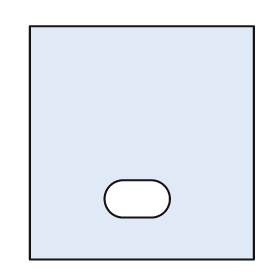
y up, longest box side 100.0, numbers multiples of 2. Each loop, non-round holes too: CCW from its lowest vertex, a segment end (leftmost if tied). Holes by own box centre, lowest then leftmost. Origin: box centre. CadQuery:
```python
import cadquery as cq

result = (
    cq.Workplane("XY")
    .moveTo(-48.0, -50.0)
    .lineTo(48.0, -50.0)
    .lineTo(48.0, 50.0)
    .lineTo(-48.0, 50.0)
    .close()
    .moveTo(-8.0, -32.0)
    .lineTo(4.0, -32.0)
    .threePointArc((12.0, -24.0), (4.0, -16.0))
    .lineTo(-8.0, -16.0)
    .threePointArc((-16.0, -24.0), (-8.0, -32.0))
    .close()
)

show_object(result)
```